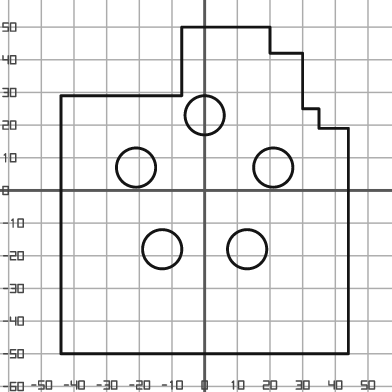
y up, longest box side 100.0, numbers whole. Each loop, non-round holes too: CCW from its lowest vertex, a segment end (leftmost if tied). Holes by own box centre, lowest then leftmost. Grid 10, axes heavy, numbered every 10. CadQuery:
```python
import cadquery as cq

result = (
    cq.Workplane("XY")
    .moveTo(-44.0, -50.0)
    .lineTo(44.0, -50.0)
    .lineTo(44.0, 19.0)
    .lineTo(35.0, 19.0)
    .lineTo(35.0, 25.0)
    .lineTo(30.0, 25.0)
    .lineTo(30.0, 42.0)
    .lineTo(20.0, 42.0)
    .lineTo(20.0, 50.0)
    .lineTo(-7.0, 50.0)
    .lineTo(-7.0, 29.0)
    .lineTo(-44.0, 29.0)
    .close()
    .moveTo(-13.0, -18.0)
    .circle(6.0)
    .moveTo(13.0, -18.0)
    .circle(6.0)
    .moveTo(-21.0, 7.0)
    .circle(6.0)
    .moveTo(21.0, 7.0)
    .circle(6.0)
    .moveTo(0.0, 23.0)
    .circle(6.0)
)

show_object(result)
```